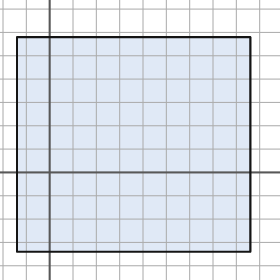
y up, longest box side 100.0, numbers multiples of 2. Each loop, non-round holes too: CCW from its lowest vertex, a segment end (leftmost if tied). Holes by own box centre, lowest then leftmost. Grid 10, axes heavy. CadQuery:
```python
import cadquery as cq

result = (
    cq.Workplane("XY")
    .moveTo(-14.0, -34.0)
    .lineTo(86.0, -34.0)
    .lineTo(86.0, 58.0)
    .lineTo(-14.0, 58.0)
    .close()
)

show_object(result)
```